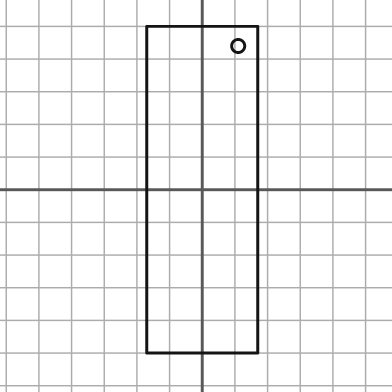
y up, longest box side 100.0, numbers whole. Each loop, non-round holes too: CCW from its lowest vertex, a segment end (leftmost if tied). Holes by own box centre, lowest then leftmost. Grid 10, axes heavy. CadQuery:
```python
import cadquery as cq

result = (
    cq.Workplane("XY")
    .moveTo(-17.0, -50.0)
    .lineTo(17.0, -50.0)
    .lineTo(17.0, 50.0)
    .lineTo(-17.0, 50.0)
    .close()
    .moveTo(11.0, 44.0)
    .circle(2.0)
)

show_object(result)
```